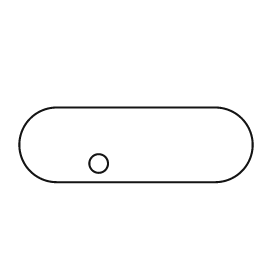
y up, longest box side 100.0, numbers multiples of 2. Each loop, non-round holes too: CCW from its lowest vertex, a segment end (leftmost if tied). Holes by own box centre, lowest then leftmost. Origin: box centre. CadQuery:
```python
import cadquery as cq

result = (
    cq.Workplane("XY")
    .moveTo(-34.0, -16.0)
    .lineTo(34.0, -16.0)
    .threePointArc((50.0, 0.0), (34.0, 16.0))
    .lineTo(-34.0, 16.0)
    .threePointArc((-50.0, 0.0), (-34.0, -16.0))
    .close()
    .moveTo(-16.0, -8.0)
    .circle(4.0)
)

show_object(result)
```